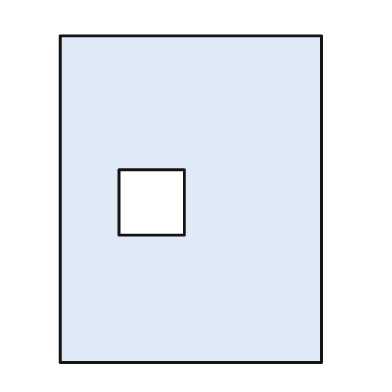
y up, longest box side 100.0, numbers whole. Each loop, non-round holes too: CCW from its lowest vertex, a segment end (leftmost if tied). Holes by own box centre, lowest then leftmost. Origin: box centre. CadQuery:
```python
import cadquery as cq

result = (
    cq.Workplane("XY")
    .moveTo(-40.0, -50.0)
    .lineTo(40.0, -50.0)
    .lineTo(40.0, 50.0)
    .lineTo(-40.0, 50.0)
    .close()
    .moveTo(-22.0, -11.0)
    .lineTo(-2.0, -11.0)
    .lineTo(-2.0, 9.0)
    .lineTo(-22.0, 9.0)
    .close()
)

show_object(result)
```